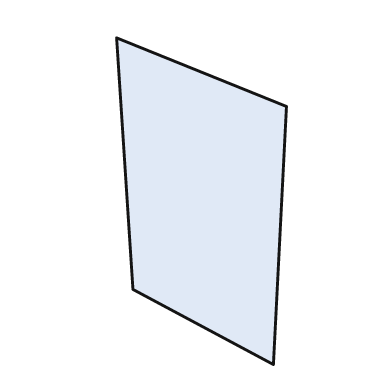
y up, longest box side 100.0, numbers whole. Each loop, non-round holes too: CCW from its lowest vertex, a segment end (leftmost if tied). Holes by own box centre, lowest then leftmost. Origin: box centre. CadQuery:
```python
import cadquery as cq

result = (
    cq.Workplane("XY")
    .moveTo(22.0, -50.0)
    .lineTo(26.0, 29.0)
    .lineTo(-26.0, 50.0)
    .lineTo(-21.0, -27.0)
    .close()
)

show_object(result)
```